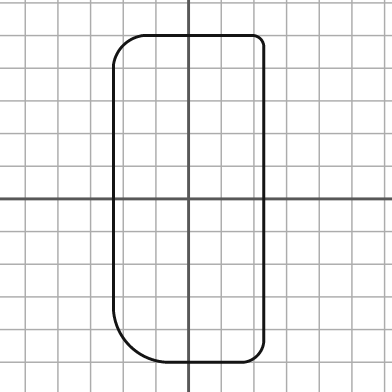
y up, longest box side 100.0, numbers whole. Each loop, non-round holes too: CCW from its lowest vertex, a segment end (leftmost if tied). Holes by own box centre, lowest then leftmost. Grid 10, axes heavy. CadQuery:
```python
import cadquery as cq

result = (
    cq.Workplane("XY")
    .moveTo(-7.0, -50.0)
    .lineTo(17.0, -50.0)
    .threePointArc((21.0, -48.0), (23.0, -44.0))
    .lineTo(23.0, 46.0)
    .threePointArc((22.0, 49.0), (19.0, 50.0))
    .lineTo(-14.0, 50.0)
    .threePointArc((-20.0, 47.0), (-23.0, 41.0))
    .lineTo(-23.0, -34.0)
    .threePointArc((-18.0, -45.0), (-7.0, -50.0))
    .close()
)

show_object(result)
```